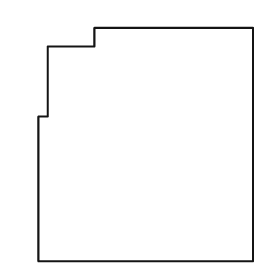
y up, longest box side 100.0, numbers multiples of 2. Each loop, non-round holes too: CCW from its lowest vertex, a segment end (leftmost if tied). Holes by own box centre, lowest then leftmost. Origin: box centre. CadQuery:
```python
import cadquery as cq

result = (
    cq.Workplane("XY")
    .moveTo(-46.0, -50.0)
    .lineTo(46.0, -50.0)
    .lineTo(46.0, 50.0)
    .lineTo(-22.0, 50.0)
    .lineTo(-22.0, 42.0)
    .lineTo(-42.0, 42.0)
    .lineTo(-42.0, 12.0)
    .lineTo(-46.0, 12.0)
    .close()
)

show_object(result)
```